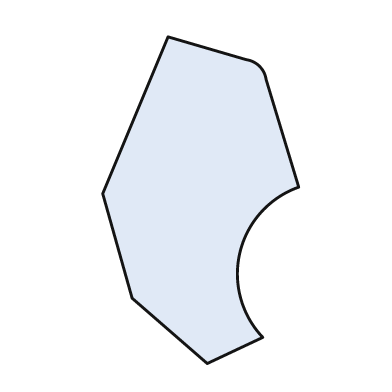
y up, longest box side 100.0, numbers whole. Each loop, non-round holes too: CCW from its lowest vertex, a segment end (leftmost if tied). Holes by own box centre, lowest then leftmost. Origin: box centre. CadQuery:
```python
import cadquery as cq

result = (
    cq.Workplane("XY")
    .moveTo(2.0, -50.0)
    .lineTo(19.0, -42.0)
    .threePointArc((12.0, -16.0), (30.0, 4.0))
    .lineTo(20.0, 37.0)
    .threePointArc((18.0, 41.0), (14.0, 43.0))
    .lineTo(-10.0, 50.0)
    .lineTo(-30.0, 2.0)
    .lineTo(-21.0, -30.0)
    .close()
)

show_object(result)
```